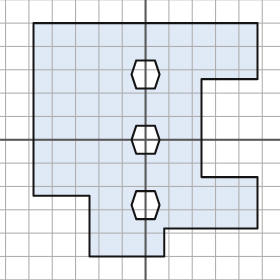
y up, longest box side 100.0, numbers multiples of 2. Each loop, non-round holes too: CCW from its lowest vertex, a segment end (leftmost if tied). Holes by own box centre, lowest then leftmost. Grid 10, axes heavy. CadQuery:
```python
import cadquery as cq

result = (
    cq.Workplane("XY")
    .moveTo(-24.0, -50.0)
    .lineTo(8.0, -50.0)
    .lineTo(8.0, -38.0)
    .lineTo(48.0, -38.0)
    .lineTo(48.0, -16.0)
    .lineTo(24.0, -16.0)
    .lineTo(24.0, 26.0)
    .lineTo(48.0, 26.0)
    .lineTo(48.0, 50.0)
    .lineTo(-48.0, 50.0)
    .lineTo(-48.0, -24.0)
    .lineTo(-24.0, -24.0)
    .close()
    .moveTo(-4.0, -34.0)
    .lineTo(4.0, -34.0)
    .lineTo(6.0, -28.0)
    .lineTo(4.0, -22.0)
    .lineTo(-4.0, -22.0)
    .lineTo(-6.0, -28.0)
    .close()
    .moveTo(-4.0, -6.0)
    .lineTo(4.0, -6.0)
    .lineTo(6.0, 0.0)
    .lineTo(4.0, 6.0)
    .lineTo(-4.0, 6.0)
    .lineTo(-6.0, 0.0)
    .close()
    .moveTo(-4.0, 22.0)
    .lineTo(4.0, 22.0)
    .lineTo(6.0, 28.0)
    .lineTo(4.0, 34.0)
    .lineTo(-4.0, 34.0)
    .lineTo(-6.0, 28.0)
    .close()
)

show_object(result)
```